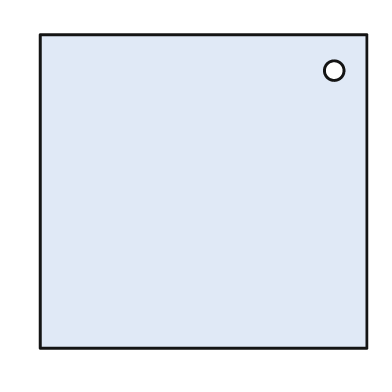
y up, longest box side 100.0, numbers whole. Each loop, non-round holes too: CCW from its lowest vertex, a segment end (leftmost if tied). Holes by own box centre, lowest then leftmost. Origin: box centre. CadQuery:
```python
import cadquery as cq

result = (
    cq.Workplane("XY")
    .moveTo(-50.0, -48.0)
    .lineTo(50.0, -48.0)
    .lineTo(50.0, 48.0)
    .lineTo(-50.0, 48.0)
    .close()
    .moveTo(40.0, 37.0)
    .circle(3.0)
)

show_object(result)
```